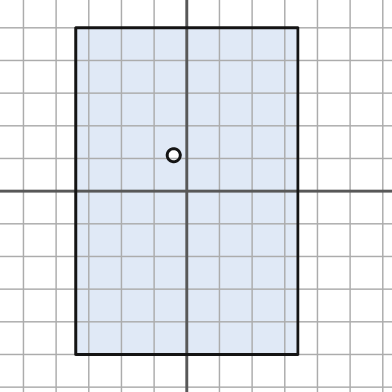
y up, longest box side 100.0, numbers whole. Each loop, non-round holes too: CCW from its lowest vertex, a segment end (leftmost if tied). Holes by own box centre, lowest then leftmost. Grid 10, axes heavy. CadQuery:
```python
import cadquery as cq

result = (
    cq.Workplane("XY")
    .moveTo(-34.0, -50.0)
    .lineTo(34.0, -50.0)
    .lineTo(34.0, 50.0)
    .lineTo(-34.0, 50.0)
    .close()
    .moveTo(-4.0, 11.0)
    .circle(2.0)
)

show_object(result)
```